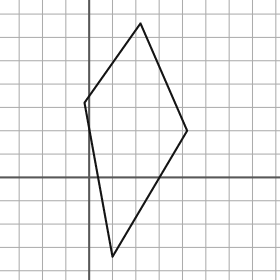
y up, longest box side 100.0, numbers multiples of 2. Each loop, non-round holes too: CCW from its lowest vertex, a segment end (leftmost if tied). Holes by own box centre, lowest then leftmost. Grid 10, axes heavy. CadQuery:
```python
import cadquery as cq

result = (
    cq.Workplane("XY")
    .moveTo(10.0, -34.0)
    .lineTo(42.0, 20.0)
    .lineTo(22.0, 66.0)
    .lineTo(-2.0, 32.0)
    .close()
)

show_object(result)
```